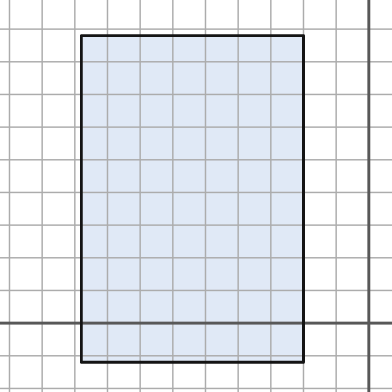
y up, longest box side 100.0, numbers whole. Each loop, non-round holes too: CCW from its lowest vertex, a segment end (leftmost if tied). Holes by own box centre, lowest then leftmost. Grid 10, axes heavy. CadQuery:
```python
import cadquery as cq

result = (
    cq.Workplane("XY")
    .moveTo(-88.0, -12.0)
    .lineTo(-20.0, -12.0)
    .lineTo(-20.0, 88.0)
    .lineTo(-88.0, 88.0)
    .close()
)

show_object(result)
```